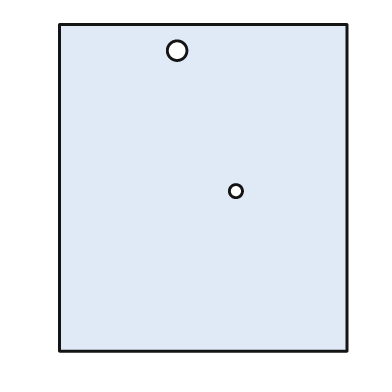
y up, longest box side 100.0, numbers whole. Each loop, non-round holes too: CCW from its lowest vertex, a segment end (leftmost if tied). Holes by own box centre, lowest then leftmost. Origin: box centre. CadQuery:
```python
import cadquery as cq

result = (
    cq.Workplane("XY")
    .moveTo(-44.0, -50.0)
    .lineTo(44.0, -50.0)
    .lineTo(44.0, 50.0)
    .lineTo(-44.0, 50.0)
    .close()
    .moveTo(10.0, -1.0)
    .circle(2.0)
    .moveTo(-8.0, 42.0)
    .circle(3.0)
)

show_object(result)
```